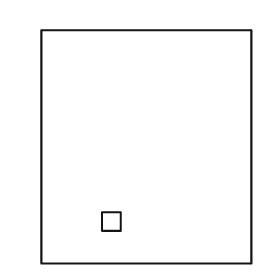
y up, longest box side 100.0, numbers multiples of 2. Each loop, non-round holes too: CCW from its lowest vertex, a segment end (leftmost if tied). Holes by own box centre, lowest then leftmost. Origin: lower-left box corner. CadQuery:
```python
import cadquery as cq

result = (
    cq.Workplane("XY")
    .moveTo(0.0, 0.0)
    .lineTo(90.0, 0.0)
    .lineTo(90.0, 100.0)
    .lineTo(0.0, 100.0)
    .close()
    .moveTo(26.0, 14.0)
    .lineTo(34.0, 14.0)
    .lineTo(34.0, 22.0)
    .lineTo(26.0, 22.0)
    .close()
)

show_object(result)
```